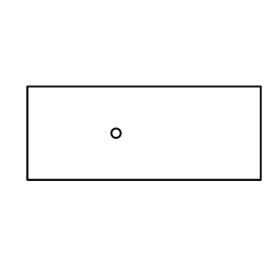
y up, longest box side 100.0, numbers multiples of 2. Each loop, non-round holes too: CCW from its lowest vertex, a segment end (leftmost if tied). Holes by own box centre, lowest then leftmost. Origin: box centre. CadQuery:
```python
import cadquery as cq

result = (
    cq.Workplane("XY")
    .moveTo(-50.0, -20.0)
    .lineTo(50.0, -20.0)
    .lineTo(50.0, 20.0)
    .lineTo(-50.0, 20.0)
    .close()
    .moveTo(-12.0, 0.0)
    .circle(2.0)
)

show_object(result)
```